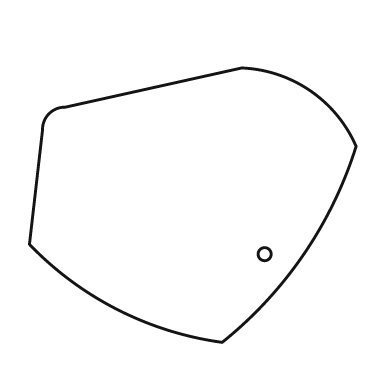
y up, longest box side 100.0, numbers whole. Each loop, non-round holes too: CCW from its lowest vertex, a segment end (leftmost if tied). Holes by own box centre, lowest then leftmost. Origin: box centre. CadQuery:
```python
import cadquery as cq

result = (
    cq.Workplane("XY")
    .moveTo(9.0, -42.0)
    .threePointArc((34.0, -15.0), (50.0, 18.0))
    .threePointArc((36.0, 35.0), (15.0, 42.0))
    .lineTo(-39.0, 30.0)
    .threePointArc((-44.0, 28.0), (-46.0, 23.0))
    .lineTo(-50.0, -12.0)
    .threePointArc((-23.0, -32.0), (9.0, -42.0))
    .close()
    .moveTo(22.0, -15.0)
    .circle(2.0)
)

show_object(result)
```